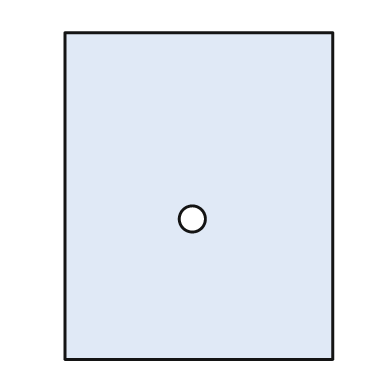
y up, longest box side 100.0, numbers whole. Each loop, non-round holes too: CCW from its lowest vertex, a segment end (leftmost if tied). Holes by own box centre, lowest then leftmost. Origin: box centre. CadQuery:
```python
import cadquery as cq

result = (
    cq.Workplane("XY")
    .moveTo(-41.0, -50.0)
    .lineTo(41.0, -50.0)
    .lineTo(41.0, 50.0)
    .lineTo(-41.0, 50.0)
    .close()
    .moveTo(-2.0, -7.0)
    .circle(4.0)
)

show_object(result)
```